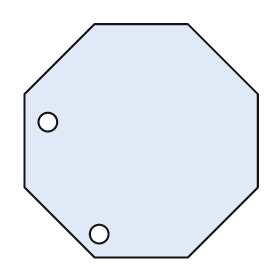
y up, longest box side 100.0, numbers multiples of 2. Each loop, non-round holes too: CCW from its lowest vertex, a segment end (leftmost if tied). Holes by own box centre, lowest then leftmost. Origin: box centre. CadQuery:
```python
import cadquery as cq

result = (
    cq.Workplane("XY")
    .moveTo(-20.0, -50.0)
    .lineTo(20.0, -50.0)
    .lineTo(50.0, -20.0)
    .lineTo(50.0, 20.0)
    .lineTo(20.0, 50.0)
    .lineTo(-20.0, 50.0)
    .lineTo(-50.0, 20.0)
    .lineTo(-50.0, -20.0)
    .close()
    .moveTo(-18.0, -40.0)
    .circle(4.0)
    .moveTo(-40.0, 8.0)
    .circle(4.0)
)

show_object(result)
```